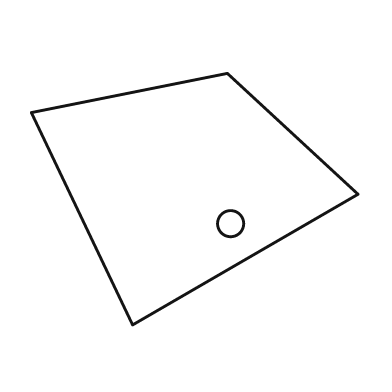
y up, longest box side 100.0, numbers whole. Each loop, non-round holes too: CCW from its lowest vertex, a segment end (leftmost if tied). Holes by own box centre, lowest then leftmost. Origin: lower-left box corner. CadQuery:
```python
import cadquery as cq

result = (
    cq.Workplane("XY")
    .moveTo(31.0, 0.0)
    .lineTo(100.0, 40.0)
    .lineTo(60.0, 77.0)
    .lineTo(0.0, 65.0)
    .close()
    .moveTo(61.0, 31.0)
    .circle(4.0)
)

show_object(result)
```